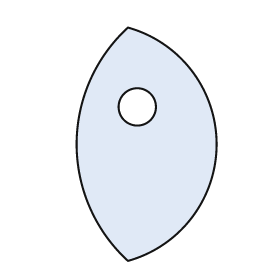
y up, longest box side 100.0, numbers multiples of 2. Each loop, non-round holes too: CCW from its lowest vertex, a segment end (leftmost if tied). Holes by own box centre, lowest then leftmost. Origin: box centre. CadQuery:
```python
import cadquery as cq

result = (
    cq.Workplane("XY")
    .moveTo(-8.0, -50.0)
    .threePointArc((30.0, 0.0), (-8.0, 50.0))
    .threePointArc((-30.0, 0.0), (-8.0, -50.0))
    .close()
    .moveTo(-4.0, 16.0)
    .circle(8.0)
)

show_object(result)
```